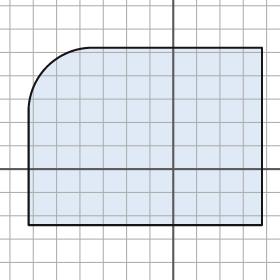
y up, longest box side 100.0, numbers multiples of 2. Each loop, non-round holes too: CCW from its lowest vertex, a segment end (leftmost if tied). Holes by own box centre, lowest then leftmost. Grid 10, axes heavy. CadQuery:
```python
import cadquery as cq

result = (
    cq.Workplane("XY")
    .moveTo(-62.0, -24.0)
    .lineTo(38.0, -24.0)
    .lineTo(38.0, 52.0)
    .lineTo(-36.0, 52.0)
    .threePointArc((-54.0, 44.0), (-62.0, 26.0))
    .close()
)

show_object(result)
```